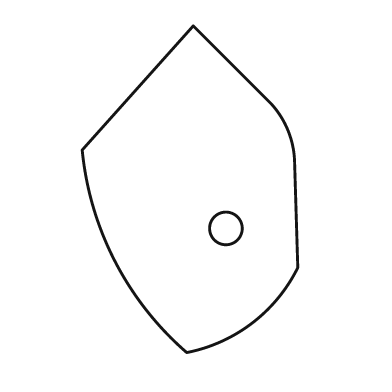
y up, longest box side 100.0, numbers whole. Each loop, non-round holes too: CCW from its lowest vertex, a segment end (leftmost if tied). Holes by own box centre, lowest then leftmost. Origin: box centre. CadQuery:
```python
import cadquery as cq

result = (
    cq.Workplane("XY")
    .moveTo(-1.0, -50.0)
    .threePointArc((19.0, -41.0), (33.0, -24.0))
    .lineTo(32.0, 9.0)
    .threePointArc((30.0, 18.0), (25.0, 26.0))
    .lineTo(1.0, 50.0)
    .lineTo(-33.0, 12.0)
    .threePointArc((-23.0, -22.0), (-1.0, -50.0))
    .close()
    .moveTo(11.0, -12.0)
    .circle(5.0)
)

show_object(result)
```